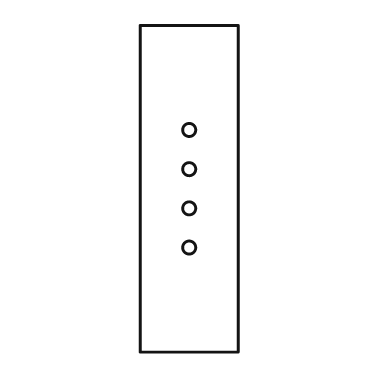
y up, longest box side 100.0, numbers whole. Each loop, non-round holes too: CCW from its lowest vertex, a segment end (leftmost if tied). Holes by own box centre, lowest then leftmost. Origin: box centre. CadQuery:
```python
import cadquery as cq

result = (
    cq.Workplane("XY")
    .moveTo(-15.0, -50.0)
    .lineTo(15.0, -50.0)
    .lineTo(15.0, 50.0)
    .lineTo(-15.0, 50.0)
    .close()
    .moveTo(0.0, -18.0)
    .circle(2.0)
    .moveTo(0.0, -6.0)
    .circle(2.0)
    .moveTo(0.0, 6.0)
    .circle(2.0)
    .moveTo(0.0, 18.0)
    .circle(2.0)
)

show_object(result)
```